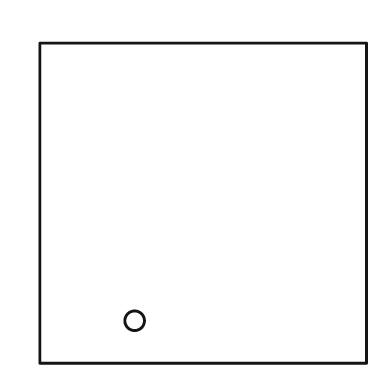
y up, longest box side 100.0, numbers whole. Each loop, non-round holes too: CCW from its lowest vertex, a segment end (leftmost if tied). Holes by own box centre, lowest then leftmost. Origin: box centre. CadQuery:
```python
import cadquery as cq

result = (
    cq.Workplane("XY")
    .moveTo(-50.0, -49.0)
    .lineTo(50.0, -49.0)
    .lineTo(50.0, 49.0)
    .lineTo(-50.0, 49.0)
    .close()
    .moveTo(-21.0, -36.0)
    .circle(3.0)
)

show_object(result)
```